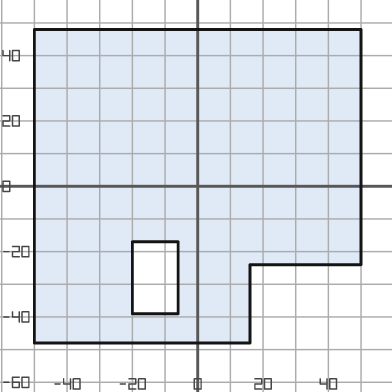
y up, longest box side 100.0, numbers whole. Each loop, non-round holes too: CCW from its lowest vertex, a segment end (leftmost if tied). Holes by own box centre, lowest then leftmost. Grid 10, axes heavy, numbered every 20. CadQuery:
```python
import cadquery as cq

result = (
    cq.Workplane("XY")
    .moveTo(-50.0, -48.0)
    .lineTo(16.0, -48.0)
    .lineTo(16.0, -24.0)
    .lineTo(50.0, -24.0)
    .lineTo(50.0, 48.0)
    .lineTo(-50.0, 48.0)
    .close()
    .moveTo(-20.0, -39.0)
    .lineTo(-6.0, -39.0)
    .lineTo(-6.0, -17.0)
    .lineTo(-20.0, -17.0)
    .close()
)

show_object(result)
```